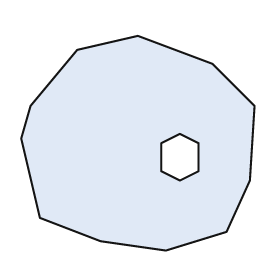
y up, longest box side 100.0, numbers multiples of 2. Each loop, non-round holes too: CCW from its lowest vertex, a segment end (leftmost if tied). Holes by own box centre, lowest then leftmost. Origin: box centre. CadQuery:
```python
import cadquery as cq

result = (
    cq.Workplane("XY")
    .moveTo(12.0, -46.0)
    .lineTo(38.0, -38.0)
    .lineTo(48.0, -16.0)
    .lineTo(50.0, 16.0)
    .lineTo(32.0, 34.0)
    .lineTo(0.0, 46.0)
    .lineTo(-26.0, 40.0)
    .lineTo(-46.0, 16.0)
    .lineTo(-50.0, 2.0)
    .lineTo(-42.0, -32.0)
    .lineTo(-16.0, -42.0)
    .close()
    .moveTo(18.0, -16.0)
    .lineTo(26.0, -12.0)
    .lineTo(26.0, 0.0)
    .lineTo(18.0, 4.0)
    .lineTo(10.0, 0.0)
    .lineTo(10.0, -12.0)
    .close()
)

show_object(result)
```